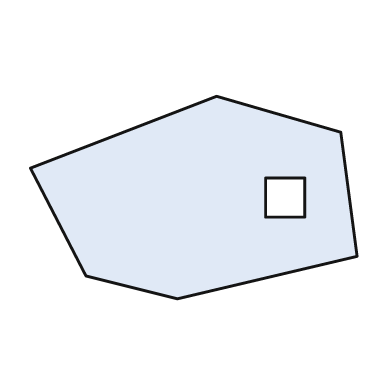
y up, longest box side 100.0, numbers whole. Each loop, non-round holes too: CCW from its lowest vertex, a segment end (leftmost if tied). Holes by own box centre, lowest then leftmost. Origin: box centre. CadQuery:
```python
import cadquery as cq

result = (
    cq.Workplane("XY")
    .moveTo(-5.0, -31.0)
    .lineTo(50.0, -18.0)
    .lineTo(45.0, 20.0)
    .lineTo(7.0, 31.0)
    .lineTo(-50.0, 9.0)
    .lineTo(-33.0, -24.0)
    .close()
    .moveTo(22.0, -6.0)
    .lineTo(34.0, -6.0)
    .lineTo(34.0, 6.0)
    .lineTo(22.0, 6.0)
    .close()
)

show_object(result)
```